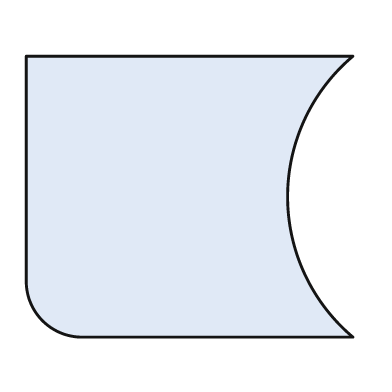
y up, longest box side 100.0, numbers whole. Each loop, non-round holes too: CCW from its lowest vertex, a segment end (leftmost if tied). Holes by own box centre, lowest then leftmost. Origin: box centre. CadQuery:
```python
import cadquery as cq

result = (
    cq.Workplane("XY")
    .moveTo(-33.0, -43.0)
    .lineTo(50.0, -43.0)
    .threePointArc((30.0, 0.0), (50.0, 43.0))
    .lineTo(-50.0, 43.0)
    .lineTo(-50.0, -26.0)
    .threePointArc((-45.0, -38.0), (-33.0, -43.0))
    .close()
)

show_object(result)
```